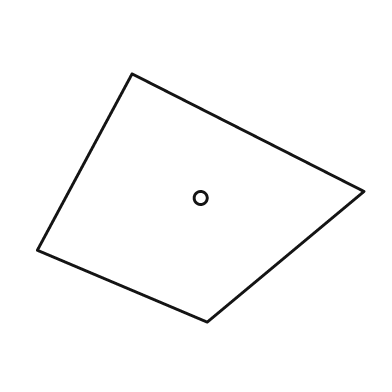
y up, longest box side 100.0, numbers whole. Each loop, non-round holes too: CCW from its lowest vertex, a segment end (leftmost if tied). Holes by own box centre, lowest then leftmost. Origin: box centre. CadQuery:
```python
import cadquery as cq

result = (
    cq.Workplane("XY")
    .moveTo(2.0, -38.0)
    .lineTo(50.0, 2.0)
    .lineTo(-21.0, 38.0)
    .lineTo(-50.0, -16.0)
    .close()
    .moveTo(0.0, 0.0)
    .circle(2.0)
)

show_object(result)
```